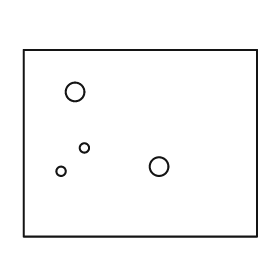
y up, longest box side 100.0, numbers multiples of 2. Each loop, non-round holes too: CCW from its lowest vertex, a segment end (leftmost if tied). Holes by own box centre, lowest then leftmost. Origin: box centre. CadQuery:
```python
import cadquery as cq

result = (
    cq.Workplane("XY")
    .moveTo(-50.0, -40.0)
    .lineTo(50.0, -40.0)
    .lineTo(50.0, 40.0)
    .lineTo(-50.0, 40.0)
    .close()
    .moveTo(-34.0, -12.0)
    .circle(2.0)
    .moveTo(8.0, -10.0)
    .circle(4.0)
    .moveTo(-24.0, -2.0)
    .circle(2.0)
    .moveTo(-28.0, 22.0)
    .circle(4.0)
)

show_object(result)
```